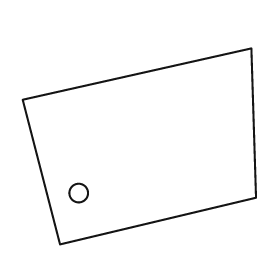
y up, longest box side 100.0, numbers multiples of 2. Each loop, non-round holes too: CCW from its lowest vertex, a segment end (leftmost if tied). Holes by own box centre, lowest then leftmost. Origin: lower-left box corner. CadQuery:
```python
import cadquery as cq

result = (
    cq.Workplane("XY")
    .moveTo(16.0, 0.0)
    .lineTo(100.0, 20.0)
    .lineTo(98.0, 84.0)
    .lineTo(0.0, 62.0)
    .close()
    .moveTo(24.0, 22.0)
    .circle(4.0)
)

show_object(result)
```